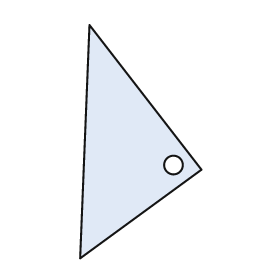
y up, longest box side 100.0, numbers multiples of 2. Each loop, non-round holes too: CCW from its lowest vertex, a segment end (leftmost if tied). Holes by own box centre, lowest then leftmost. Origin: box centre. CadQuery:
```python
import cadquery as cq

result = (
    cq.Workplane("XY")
    .moveTo(-26.0, -50.0)
    .lineTo(26.0, -12.0)
    .lineTo(-22.0, 50.0)
    .close()
    .moveTo(14.0, -10.0)
    .circle(4.0)
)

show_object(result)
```